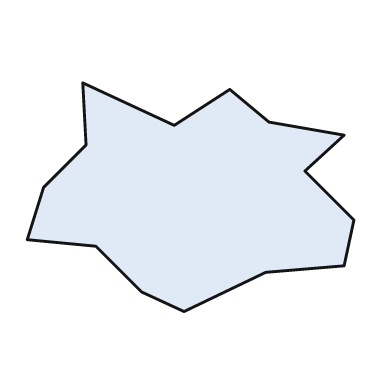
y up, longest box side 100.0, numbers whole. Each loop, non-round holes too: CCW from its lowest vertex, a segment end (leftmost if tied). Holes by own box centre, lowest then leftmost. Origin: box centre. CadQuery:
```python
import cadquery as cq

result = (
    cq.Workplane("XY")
    .moveTo(-2.0, -35.0)
    .lineTo(23.0, -23.0)
    .lineTo(47.0, -21.0)
    .lineTo(50.0, -7.0)
    .lineTo(35.0, 8.0)
    .lineTo(47.0, 19.0)
    .lineTo(24.0, 23.0)
    .lineTo(12.0, 33.0)
    .lineTo(-5.0, 22.0)
    .lineTo(-33.0, 35.0)
    .lineTo(-32.0, 16.0)
    .lineTo(-45.0, 3.0)
    .lineTo(-50.0, -13.0)
    .lineTo(-29.0, -15.0)
    .lineTo(-15.0, -29.0)
    .close()
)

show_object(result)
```